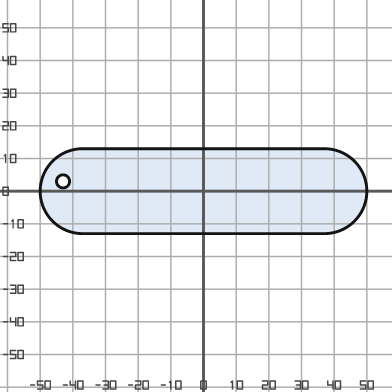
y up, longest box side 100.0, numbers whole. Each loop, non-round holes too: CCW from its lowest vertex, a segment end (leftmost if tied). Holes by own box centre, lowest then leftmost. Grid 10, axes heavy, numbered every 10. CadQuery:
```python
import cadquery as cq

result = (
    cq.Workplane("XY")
    .moveTo(-37.0, -13.0)
    .lineTo(37.0, -13.0)
    .threePointArc((50.0, 0.0), (37.0, 13.0))
    .lineTo(-37.0, 13.0)
    .threePointArc((-50.0, 0.0), (-37.0, -13.0))
    .close()
    .moveTo(-43.0, 3.0)
    .circle(2.0)
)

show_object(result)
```